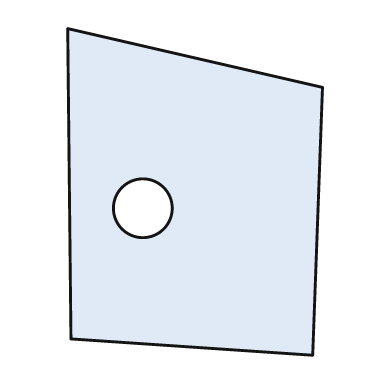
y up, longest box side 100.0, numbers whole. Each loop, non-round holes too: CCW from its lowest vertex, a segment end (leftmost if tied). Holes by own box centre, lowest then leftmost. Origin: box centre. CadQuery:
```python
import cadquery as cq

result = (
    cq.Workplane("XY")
    .moveTo(36.0, -50.0)
    .lineTo(39.0, 32.0)
    .lineTo(-39.0, 50.0)
    .lineTo(-38.0, -45.0)
    .close()
    .moveTo(-16.0, -5.0)
    .circle(9.0)
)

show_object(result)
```